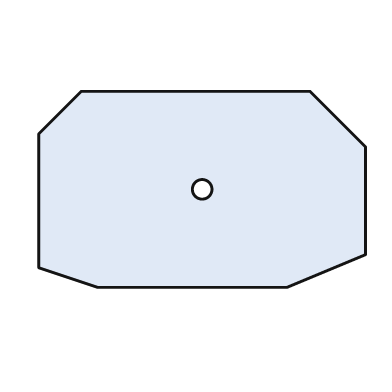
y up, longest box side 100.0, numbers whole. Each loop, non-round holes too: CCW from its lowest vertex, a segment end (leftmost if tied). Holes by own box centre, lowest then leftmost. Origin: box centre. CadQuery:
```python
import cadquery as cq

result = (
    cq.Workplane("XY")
    .moveTo(-32.0, -30.0)
    .lineTo(26.0, -30.0)
    .lineTo(50.0, -20.0)
    .lineTo(50.0, 13.0)
    .lineTo(33.0, 30.0)
    .lineTo(-37.0, 30.0)
    .lineTo(-50.0, 17.0)
    .lineTo(-50.0, -24.0)
    .close()
    .moveTo(0.0, 0.0)
    .circle(3.0)
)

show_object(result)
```